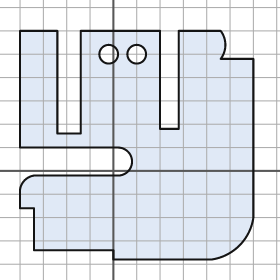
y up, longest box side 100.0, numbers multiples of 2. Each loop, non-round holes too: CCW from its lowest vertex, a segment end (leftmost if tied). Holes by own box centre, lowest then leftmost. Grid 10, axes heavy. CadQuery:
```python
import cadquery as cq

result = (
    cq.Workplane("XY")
    .moveTo(0.0, -38.0)
    .lineTo(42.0, -38.0)
    .threePointArc((54.0, -32.0), (60.0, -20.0))
    .lineTo(60.0, 48.0)
    .lineTo(46.0, 48.0)
    .threePointArc((48.0, 54.0), (46.0, 60.0))
    .lineTo(28.0, 60.0)
    .lineTo(28.0, 18.0)
    .lineTo(20.0, 18.0)
    .lineTo(20.0, 60.0)
    .lineTo(-14.0, 60.0)
    .lineTo(-14.0, 16.0)
    .lineTo(-24.0, 16.0)
    .lineTo(-24.0, 60.0)
    .lineTo(-40.0, 60.0)
    .lineTo(-40.0, 10.0)
    .lineTo(2.0, 10.0)
    .threePointArc((8.0, 4.0), (2.0, -2.0))
    .lineTo(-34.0, -2.0)
    .threePointArc((-38.0, -4.0), (-40.0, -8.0))
    .lineTo(-40.0, -16.0)
    .lineTo(-34.0, -16.0)
    .lineTo(-34.0, -34.0)
    .lineTo(0.0, -34.0)
    .close()
    .moveTo(-2.0, 50.0)
    .circle(4.0)
    .moveTo(10.0, 50.0)
    .circle(4.0)
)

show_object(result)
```